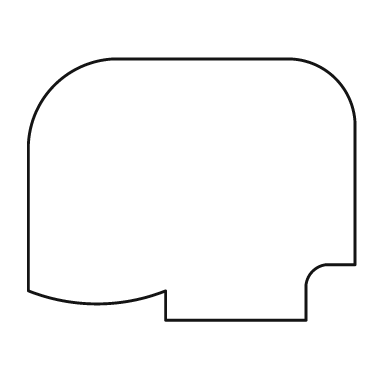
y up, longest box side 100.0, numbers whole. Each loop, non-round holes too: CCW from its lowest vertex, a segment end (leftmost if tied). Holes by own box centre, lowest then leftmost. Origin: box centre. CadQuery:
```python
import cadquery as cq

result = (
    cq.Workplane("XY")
    .moveTo(-8.0, -40.0)
    .lineTo(35.0, -40.0)
    .lineTo(35.0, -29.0)
    .threePointArc((37.0, -25.0), (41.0, -23.0))
    .lineTo(50.0, -23.0)
    .lineTo(50.0, 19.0)
    .threePointArc((44.0, 34.0), (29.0, 40.0))
    .lineTo(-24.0, 40.0)
    .threePointArc((-42.0, 32.0), (-50.0, 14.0))
    .lineTo(-50.0, -31.0)
    .threePointArc((-29.0, -35.0), (-8.0, -31.0))
    .close()
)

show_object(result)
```